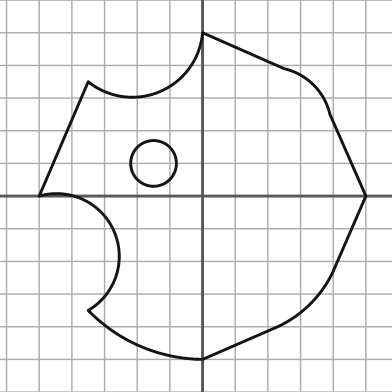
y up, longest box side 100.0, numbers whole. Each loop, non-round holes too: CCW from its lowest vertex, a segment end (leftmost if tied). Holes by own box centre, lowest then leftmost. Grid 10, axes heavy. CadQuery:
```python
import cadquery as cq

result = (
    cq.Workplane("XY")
    .moveTo(0.0, -50.0)
    .lineTo(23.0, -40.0)
    .threePointArc((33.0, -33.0), (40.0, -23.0))
    .lineTo(50.0, 0.0)
    .lineTo(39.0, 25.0)
    .threePointArc((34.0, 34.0), (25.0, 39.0))
    .lineTo(0.0, 50.0)
    .threePointArc((-13.0, 32.0), (-35.0, 35.0))
    .lineTo(-50.0, 0.0)
    .threePointArc((-27.0, -11.0), (-35.0, -35.0))
    .threePointArc((-19.0, -46.0), (0.0, -50.0))
    .close()
    .moveTo(-15.0, 10.0)
    .circle(7.0)
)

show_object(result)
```